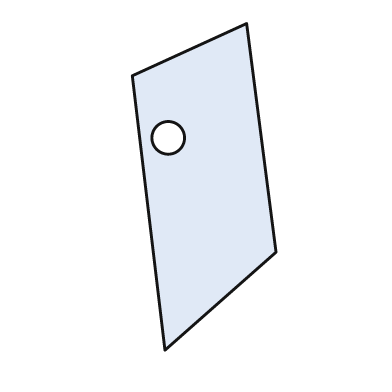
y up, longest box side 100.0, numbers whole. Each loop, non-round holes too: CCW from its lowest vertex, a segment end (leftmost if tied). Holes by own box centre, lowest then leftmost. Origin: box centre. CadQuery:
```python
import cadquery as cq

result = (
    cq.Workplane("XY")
    .moveTo(-12.0, -50.0)
    .lineTo(22.0, -20.0)
    .lineTo(13.0, 50.0)
    .lineTo(-22.0, 34.0)
    .close()
    .moveTo(-11.0, 15.0)
    .circle(5.0)
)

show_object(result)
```